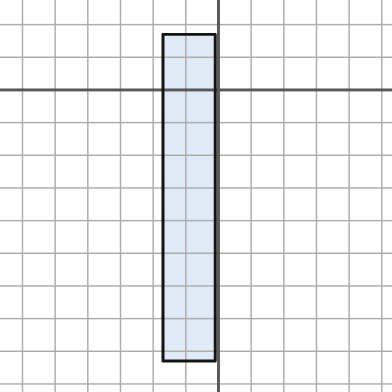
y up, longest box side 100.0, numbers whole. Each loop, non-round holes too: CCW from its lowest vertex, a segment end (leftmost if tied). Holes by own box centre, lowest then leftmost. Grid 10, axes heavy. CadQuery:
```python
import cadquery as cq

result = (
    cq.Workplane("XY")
    .moveTo(-17.0, -83.0)
    .lineTo(-1.0, -83.0)
    .lineTo(-1.0, 17.0)
    .lineTo(-17.0, 17.0)
    .close()
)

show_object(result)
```